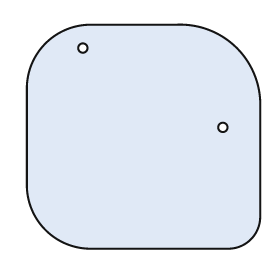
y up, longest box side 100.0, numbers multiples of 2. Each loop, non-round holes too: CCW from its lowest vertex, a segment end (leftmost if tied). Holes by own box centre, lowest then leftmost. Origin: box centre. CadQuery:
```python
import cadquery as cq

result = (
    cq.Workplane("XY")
    .moveTo(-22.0, -48.0)
    .lineTo(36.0, -48.0)
    .threePointArc((46.0, -44.0), (50.0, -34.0))
    .lineTo(50.0, 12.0)
    .threePointArc((40.0, 38.0), (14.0, 48.0))
    .lineTo(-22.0, 48.0)
    .threePointArc((-42.0, 40.0), (-50.0, 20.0))
    .lineTo(-50.0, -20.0)
    .threePointArc((-42.0, -40.0), (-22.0, -48.0))
    .close()
    .moveTo(34.0, 4.0)
    .circle(2.0)
    .moveTo(-26.0, 38.0)
    .circle(2.0)
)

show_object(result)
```